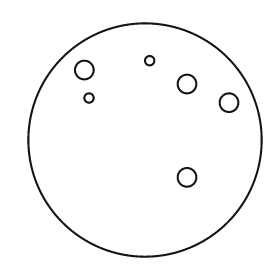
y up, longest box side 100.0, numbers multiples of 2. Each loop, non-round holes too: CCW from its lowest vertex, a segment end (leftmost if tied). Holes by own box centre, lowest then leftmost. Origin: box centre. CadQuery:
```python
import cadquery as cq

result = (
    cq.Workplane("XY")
    .moveTo(0.0, 0.0)
    .circle(50.0)
    .moveTo(18.0, -16.0)
    .circle(4.0)
    .moveTo(36.0, 16.0)
    .circle(4.0)
    .moveTo(-24.0, 18.0)
    .circle(2.0)
    .moveTo(18.0, 24.0)
    .circle(4.0)
    .moveTo(-26.0, 30.0)
    .circle(4.0)
    .moveTo(2.0, 34.0)
    .circle(2.0)
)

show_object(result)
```